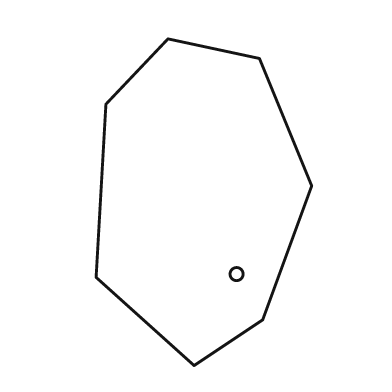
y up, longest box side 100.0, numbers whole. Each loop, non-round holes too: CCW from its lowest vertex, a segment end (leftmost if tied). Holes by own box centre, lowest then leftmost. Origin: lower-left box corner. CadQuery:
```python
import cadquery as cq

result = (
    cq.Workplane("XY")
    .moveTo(30.0, 0.0)
    .lineTo(51.0, 14.0)
    .lineTo(66.0, 55.0)
    .lineTo(50.0, 94.0)
    .lineTo(22.0, 100.0)
    .lineTo(3.0, 80.0)
    .lineTo(0.0, 27.0)
    .close()
    .moveTo(43.0, 28.0)
    .circle(2.0)
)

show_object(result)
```